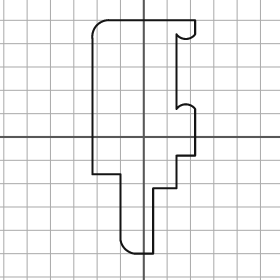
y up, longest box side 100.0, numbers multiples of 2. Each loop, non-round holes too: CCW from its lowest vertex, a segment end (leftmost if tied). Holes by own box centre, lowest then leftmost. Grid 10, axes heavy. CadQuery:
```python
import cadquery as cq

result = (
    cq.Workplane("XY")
    .moveTo(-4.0, -50.0)
    .lineTo(4.0, -50.0)
    .lineTo(4.0, -22.0)
    .lineTo(14.0, -22.0)
    .lineTo(14.0, -8.0)
    .lineTo(22.0, -8.0)
    .lineTo(22.0, 12.0)
    .threePointArc((18.0, 14.0), (14.0, 12.0))
    .lineTo(14.0, 44.0)
    .threePointArc((18.0, 42.0), (22.0, 44.0))
    .lineTo(22.0, 50.0)
    .lineTo(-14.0, 50.0)
    .threePointArc((-20.0, 48.0), (-22.0, 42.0))
    .lineTo(-22.0, -16.0)
    .lineTo(-10.0, -16.0)
    .lineTo(-10.0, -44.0)
    .threePointArc((-8.0, -48.0), (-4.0, -50.0))
    .close()
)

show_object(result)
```